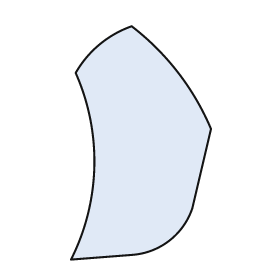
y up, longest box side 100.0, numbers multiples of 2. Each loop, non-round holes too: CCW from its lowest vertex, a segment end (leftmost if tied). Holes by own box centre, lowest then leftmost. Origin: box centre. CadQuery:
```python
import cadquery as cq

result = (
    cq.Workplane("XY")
    .moveTo(-30.0, -50.0)
    .lineTo(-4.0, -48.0)
    .threePointArc((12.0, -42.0), (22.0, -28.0))
    .lineTo(30.0, 6.0)
    .threePointArc((16.0, 30.0), (-4.0, 50.0))
    .threePointArc((-18.0, 42.0), (-28.0, 30.0))
    .threePointArc((-20.0, -10.0), (-30.0, -50.0))
    .close()
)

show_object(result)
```